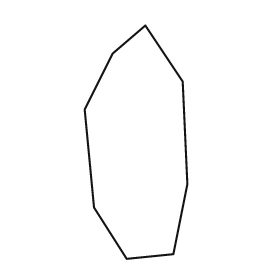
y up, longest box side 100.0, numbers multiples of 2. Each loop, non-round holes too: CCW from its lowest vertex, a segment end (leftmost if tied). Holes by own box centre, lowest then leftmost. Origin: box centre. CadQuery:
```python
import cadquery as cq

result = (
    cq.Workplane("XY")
    .moveTo(-4.0, -50.0)
    .lineTo(16.0, -48.0)
    .lineTo(22.0, -18.0)
    .lineTo(20.0, 26.0)
    .lineTo(4.0, 50.0)
    .lineTo(-10.0, 38.0)
    .lineTo(-22.0, 14.0)
    .lineTo(-18.0, -28.0)
    .close()
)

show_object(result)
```